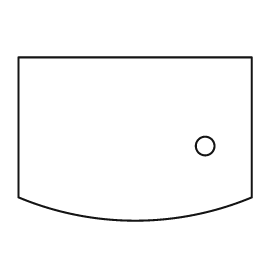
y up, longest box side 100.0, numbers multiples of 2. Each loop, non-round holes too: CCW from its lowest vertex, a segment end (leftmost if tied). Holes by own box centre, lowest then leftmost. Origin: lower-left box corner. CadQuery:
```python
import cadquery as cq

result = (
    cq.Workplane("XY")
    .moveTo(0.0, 10.0)
    .threePointArc((50.0, 0.0), (100.0, 10.0))
    .lineTo(100.0, 70.0)
    .lineTo(0.0, 70.0)
    .close()
    .moveTo(80.0, 32.0)
    .circle(4.0)
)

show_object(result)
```